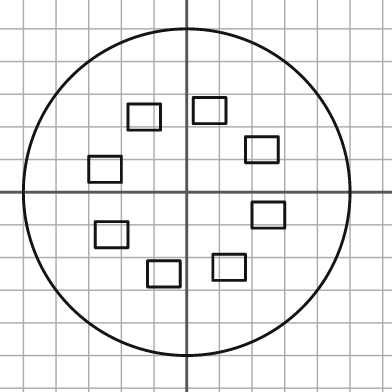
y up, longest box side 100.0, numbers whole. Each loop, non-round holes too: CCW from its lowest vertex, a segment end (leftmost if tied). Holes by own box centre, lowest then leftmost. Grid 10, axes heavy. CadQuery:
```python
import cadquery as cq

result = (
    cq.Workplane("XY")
    .moveTo(0.0, 0.0)
    .circle(50.0)
    .moveTo(-12.0, -29.0)
    .lineTo(-2.0, -29.0)
    .lineTo(-2.0, -21.0)
    .lineTo(-12.0, -21.0)
    .close()
    .moveTo(8.0, -27.0)
    .lineTo(18.0, -27.0)
    .lineTo(18.0, -19.0)
    .lineTo(8.0, -19.0)
    .close()
    .moveTo(-28.0, -17.0)
    .lineTo(-18.0, -17.0)
    .lineTo(-18.0, -9.0)
    .lineTo(-28.0, -9.0)
    .close()
    .moveTo(20.0, -11.0)
    .lineTo(30.0, -11.0)
    .lineTo(30.0, -3.0)
    .lineTo(20.0, -3.0)
    .close()
    .moveTo(-30.0, 3.0)
    .lineTo(-20.0, 3.0)
    .lineTo(-20.0, 11.0)
    .lineTo(-30.0, 11.0)
    .close()
    .moveTo(18.0, 9.0)
    .lineTo(28.0, 9.0)
    .lineTo(28.0, 17.0)
    .lineTo(18.0, 17.0)
    .close()
    .moveTo(-18.0, 19.0)
    .lineTo(-8.0, 19.0)
    .lineTo(-8.0, 27.0)
    .lineTo(-18.0, 27.0)
    .close()
    .moveTo(2.0, 21.0)
    .lineTo(12.0, 21.0)
    .lineTo(12.0, 29.0)
    .lineTo(2.0, 29.0)
    .close()
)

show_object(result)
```